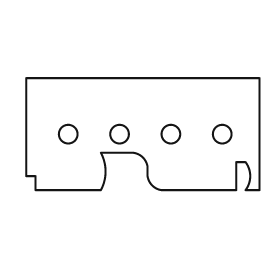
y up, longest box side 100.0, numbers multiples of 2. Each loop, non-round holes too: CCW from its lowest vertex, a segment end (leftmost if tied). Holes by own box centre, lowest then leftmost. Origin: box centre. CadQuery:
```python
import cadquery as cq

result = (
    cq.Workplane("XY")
    .moveTo(-46.0, -24.0)
    .lineTo(-18.0, -24.0)
    .threePointArc((-16.0, -16.0), (-18.0, -8.0))
    .lineTo(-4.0, -8.0)
    .threePointArc((0.0, -10.0), (2.0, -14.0))
    .lineTo(2.0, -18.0)
    .threePointArc((4.0, -22.0), (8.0, -24.0))
    .lineTo(40.0, -24.0)
    .lineTo(40.0, -12.0)
    .lineTo(44.0, -12.0)
    .threePointArc((46.0, -18.0), (44.0, -24.0))
    .lineTo(50.0, -24.0)
    .lineTo(50.0, 24.0)
    .lineTo(-50.0, 24.0)
    .lineTo(-50.0, -18.0)
    .lineTo(-46.0, -18.0)
    .close()
    .moveTo(-32.0, 0.0)
    .circle(4.0)
    .moveTo(-10.0, 0.0)
    .circle(4.0)
    .moveTo(12.0, 0.0)
    .circle(4.0)
    .moveTo(34.0, 0.0)
    .circle(4.0)
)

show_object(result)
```